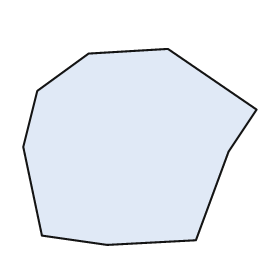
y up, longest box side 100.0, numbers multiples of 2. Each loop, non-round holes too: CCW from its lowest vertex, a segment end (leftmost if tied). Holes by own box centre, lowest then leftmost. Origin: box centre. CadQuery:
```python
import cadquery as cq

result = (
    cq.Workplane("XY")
    .moveTo(-14.0, -42.0)
    .lineTo(24.0, -40.0)
    .lineTo(38.0, -2.0)
    .lineTo(50.0, 16.0)
    .lineTo(12.0, 42.0)
    .lineTo(-22.0, 40.0)
    .lineTo(-44.0, 24.0)
    .lineTo(-50.0, 0.0)
    .lineTo(-42.0, -38.0)
    .close()
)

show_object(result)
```